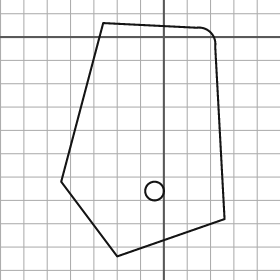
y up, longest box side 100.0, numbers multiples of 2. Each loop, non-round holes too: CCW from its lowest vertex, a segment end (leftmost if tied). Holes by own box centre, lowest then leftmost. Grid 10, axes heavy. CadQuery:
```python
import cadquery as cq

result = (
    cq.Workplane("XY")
    .moveTo(-20.0, -94.0)
    .lineTo(26.0, -78.0)
    .lineTo(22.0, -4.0)
    .threePointArc((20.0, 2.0), (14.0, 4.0))
    .lineTo(-26.0, 6.0)
    .lineTo(-44.0, -62.0)
    .close()
    .moveTo(-4.0, -66.0)
    .circle(4.0)
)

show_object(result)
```